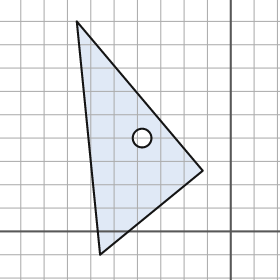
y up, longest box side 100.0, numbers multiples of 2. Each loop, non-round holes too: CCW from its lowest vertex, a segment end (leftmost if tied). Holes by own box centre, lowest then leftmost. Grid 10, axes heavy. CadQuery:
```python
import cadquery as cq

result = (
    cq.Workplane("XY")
    .moveTo(-56.0, -10.0)
    .lineTo(-12.0, 26.0)
    .lineTo(-66.0, 90.0)
    .close()
    .moveTo(-38.0, 40.0)
    .circle(4.0)
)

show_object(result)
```